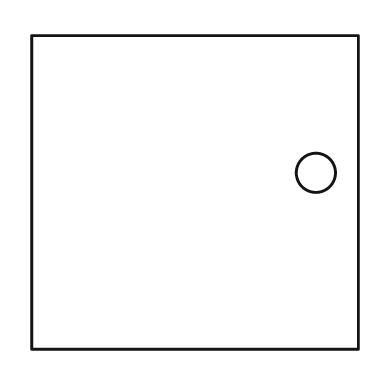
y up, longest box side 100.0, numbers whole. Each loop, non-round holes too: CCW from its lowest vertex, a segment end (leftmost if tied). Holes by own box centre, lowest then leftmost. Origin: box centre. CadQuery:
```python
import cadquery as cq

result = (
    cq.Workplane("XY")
    .moveTo(-50.0, -48.0)
    .lineTo(50.0, -48.0)
    .lineTo(50.0, 48.0)
    .lineTo(-50.0, 48.0)
    .close()
    .moveTo(37.0, 6.0)
    .circle(6.0)
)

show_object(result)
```